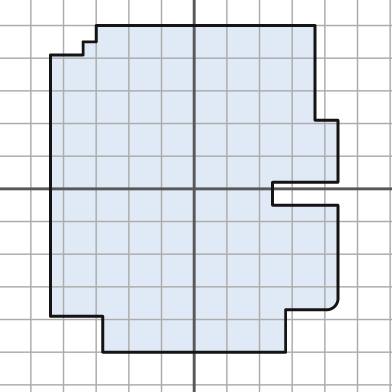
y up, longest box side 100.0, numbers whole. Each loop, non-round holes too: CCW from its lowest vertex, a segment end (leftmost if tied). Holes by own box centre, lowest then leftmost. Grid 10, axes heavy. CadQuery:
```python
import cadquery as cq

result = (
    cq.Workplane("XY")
    .moveTo(-28.0, -50.0)
    .lineTo(28.0, -50.0)
    .lineTo(28.0, -37.0)
    .lineTo(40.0, -37.0)
    .threePointArc((43.0, -36.0), (44.0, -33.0))
    .lineTo(44.0, -5.0)
    .lineTo(24.0, -5.0)
    .lineTo(24.0, 2.0)
    .lineTo(44.0, 2.0)
    .lineTo(44.0, 21.0)
    .lineTo(37.0, 21.0)
    .lineTo(37.0, 50.0)
    .lineTo(-30.0, 50.0)
    .lineTo(-30.0, 45.0)
    .lineTo(-34.0, 45.0)
    .lineTo(-34.0, 41.0)
    .lineTo(-44.0, 41.0)
    .lineTo(-44.0, -39.0)
    .lineTo(-28.0, -39.0)
    .close()
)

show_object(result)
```